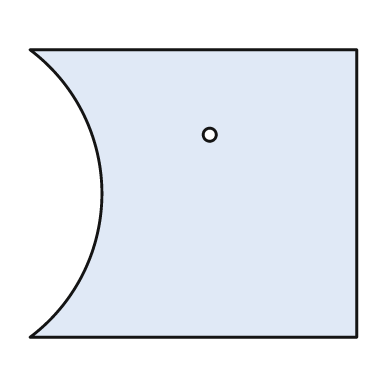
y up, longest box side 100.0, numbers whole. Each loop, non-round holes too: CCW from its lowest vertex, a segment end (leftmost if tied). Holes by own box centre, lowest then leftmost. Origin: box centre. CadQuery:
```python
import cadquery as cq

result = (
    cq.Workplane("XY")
    .moveTo(-50.0, -44.0)
    .lineTo(50.0, -44.0)
    .lineTo(50.0, 44.0)
    .lineTo(-50.0, 44.0)
    .threePointArc((-28.0, 0.0), (-50.0, -44.0))
    .close()
    .moveTo(5.0, 18.0)
    .circle(2.0)
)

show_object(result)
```